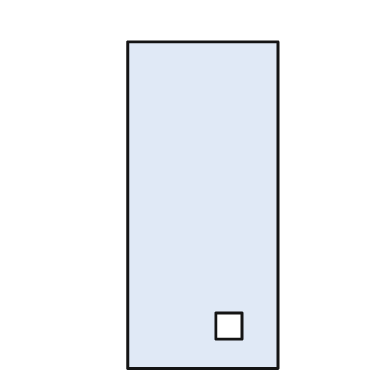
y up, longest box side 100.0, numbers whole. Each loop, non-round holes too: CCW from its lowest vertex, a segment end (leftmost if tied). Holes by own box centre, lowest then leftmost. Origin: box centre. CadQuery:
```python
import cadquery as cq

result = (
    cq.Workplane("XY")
    .moveTo(-23.0, -50.0)
    .lineTo(23.0, -50.0)
    .lineTo(23.0, 50.0)
    .lineTo(-23.0, 50.0)
    .close()
    .moveTo(4.0, -41.0)
    .lineTo(12.0, -41.0)
    .lineTo(12.0, -33.0)
    .lineTo(4.0, -33.0)
    .close()
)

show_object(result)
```